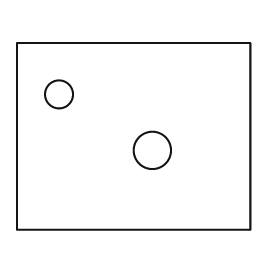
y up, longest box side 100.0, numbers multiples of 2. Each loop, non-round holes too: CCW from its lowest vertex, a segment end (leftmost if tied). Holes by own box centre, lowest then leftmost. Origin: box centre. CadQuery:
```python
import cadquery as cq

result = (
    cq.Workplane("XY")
    .moveTo(-50.0, -40.0)
    .lineTo(50.0, -40.0)
    .lineTo(50.0, 40.0)
    .lineTo(-50.0, 40.0)
    .close()
    .moveTo(8.0, -6.0)
    .circle(8.0)
    .moveTo(-32.0, 18.0)
    .circle(6.0)
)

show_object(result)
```